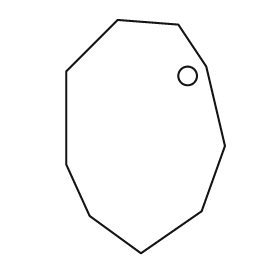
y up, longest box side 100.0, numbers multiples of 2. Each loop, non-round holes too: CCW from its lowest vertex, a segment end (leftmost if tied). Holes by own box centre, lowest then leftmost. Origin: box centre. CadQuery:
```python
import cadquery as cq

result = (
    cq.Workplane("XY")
    .moveTo(-2.0, -50.0)
    .lineTo(24.0, -32.0)
    .lineTo(34.0, -4.0)
    .lineTo(26.0, 30.0)
    .lineTo(14.0, 48.0)
    .lineTo(-12.0, 50.0)
    .lineTo(-34.0, 28.0)
    .lineTo(-34.0, -12.0)
    .lineTo(-24.0, -34.0)
    .close()
    .moveTo(18.0, 26.0)
    .circle(4.0)
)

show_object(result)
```